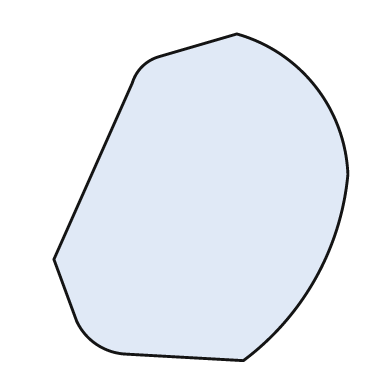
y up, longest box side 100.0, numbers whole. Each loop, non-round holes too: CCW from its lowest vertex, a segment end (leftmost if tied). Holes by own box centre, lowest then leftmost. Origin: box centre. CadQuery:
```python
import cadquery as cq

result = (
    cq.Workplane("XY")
    .moveTo(13.0, -50.0)
    .threePointArc((35.0, -25.0), (45.0, 7.0))
    .threePointArc((35.0, 34.0), (11.0, 50.0))
    .lineTo(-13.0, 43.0)
    .threePointArc((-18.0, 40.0), (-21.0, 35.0))
    .lineTo(-45.0, -19.0)
    .lineTo(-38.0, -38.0)
    .threePointArc((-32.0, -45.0), (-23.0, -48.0))
    .close()
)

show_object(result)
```